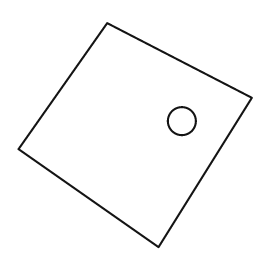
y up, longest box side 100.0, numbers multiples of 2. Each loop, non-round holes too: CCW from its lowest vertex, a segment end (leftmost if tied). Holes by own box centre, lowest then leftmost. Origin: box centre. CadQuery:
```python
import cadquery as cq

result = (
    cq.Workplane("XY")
    .moveTo(10.0, -48.0)
    .lineTo(50.0, 16.0)
    .lineTo(-12.0, 48.0)
    .lineTo(-50.0, -6.0)
    .close()
    .moveTo(20.0, 6.0)
    .circle(6.0)
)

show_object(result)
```